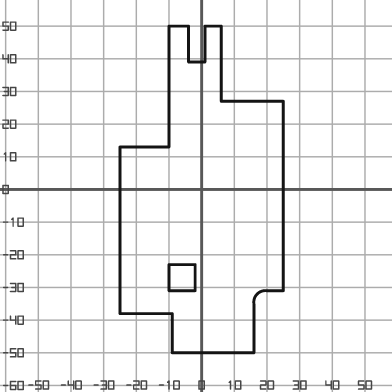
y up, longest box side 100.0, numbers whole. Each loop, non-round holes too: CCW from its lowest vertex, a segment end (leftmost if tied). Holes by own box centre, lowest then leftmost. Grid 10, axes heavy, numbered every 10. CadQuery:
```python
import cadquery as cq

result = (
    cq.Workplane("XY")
    .moveTo(-9.0, -50.0)
    .lineTo(16.0, -50.0)
    .lineTo(16.0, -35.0)
    .threePointArc((17.0, -32.0), (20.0, -31.0))
    .lineTo(25.0, -31.0)
    .lineTo(25.0, 27.0)
    .lineTo(6.0, 27.0)
    .lineTo(6.0, 50.0)
    .lineTo(1.0, 50.0)
    .lineTo(1.0, 39.0)
    .lineTo(-4.0, 39.0)
    .lineTo(-4.0, 50.0)
    .lineTo(-10.0, 50.0)
    .lineTo(-10.0, 13.0)
    .lineTo(-25.0, 13.0)
    .lineTo(-25.0, -38.0)
    .lineTo(-9.0, -38.0)
    .close()
    .moveTo(-10.0, -31.0)
    .lineTo(-2.0, -31.0)
    .lineTo(-2.0, -23.0)
    .lineTo(-10.0, -23.0)
    .close()
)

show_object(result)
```